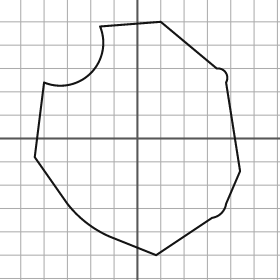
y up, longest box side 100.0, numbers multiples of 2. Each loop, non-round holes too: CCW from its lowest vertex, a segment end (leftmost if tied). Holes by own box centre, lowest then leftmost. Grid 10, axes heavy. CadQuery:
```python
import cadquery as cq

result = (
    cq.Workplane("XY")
    .moveTo(8.0, -50.0)
    .lineTo(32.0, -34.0)
    .threePointArc((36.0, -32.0), (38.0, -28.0))
    .lineTo(44.0, -14.0)
    .lineTo(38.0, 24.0)
    .threePointArc((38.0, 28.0), (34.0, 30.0))
    .lineTo(10.0, 50.0)
    .lineTo(-16.0, 48.0)
    .threePointArc((-20.0, 28.0), (-40.0, 24.0))
    .lineTo(-44.0, -8.0)
    .lineTo(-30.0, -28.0)
    .threePointArc((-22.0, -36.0), (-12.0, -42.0))
    .close()
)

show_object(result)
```